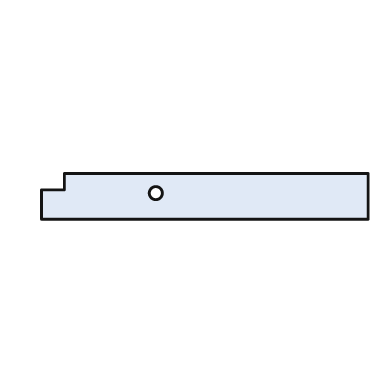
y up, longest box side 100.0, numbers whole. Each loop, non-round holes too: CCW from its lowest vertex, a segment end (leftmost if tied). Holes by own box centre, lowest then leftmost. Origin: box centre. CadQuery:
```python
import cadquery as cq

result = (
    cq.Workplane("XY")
    .moveTo(-50.0, -7.0)
    .lineTo(50.0, -7.0)
    .lineTo(50.0, 7.0)
    .lineTo(-43.0, 7.0)
    .lineTo(-43.0, 2.0)
    .lineTo(-50.0, 2.0)
    .close()
    .moveTo(-15.0, 1.0)
    .circle(2.0)
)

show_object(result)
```